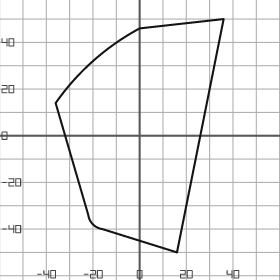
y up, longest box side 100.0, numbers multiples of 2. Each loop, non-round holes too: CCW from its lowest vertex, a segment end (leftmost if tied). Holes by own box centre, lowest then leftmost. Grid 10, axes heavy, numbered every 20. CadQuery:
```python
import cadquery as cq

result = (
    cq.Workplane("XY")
    .moveTo(16.0, -50.0)
    .lineTo(36.0, 50.0)
    .lineTo(0.0, 46.0)
    .threePointArc((-20.0, 32.0), (-36.0, 14.0))
    .lineTo(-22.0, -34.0)
    .threePointArc((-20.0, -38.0), (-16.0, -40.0))
    .close()
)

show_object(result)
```